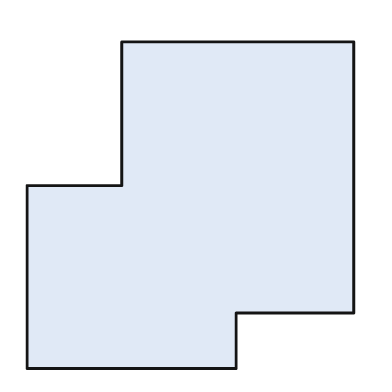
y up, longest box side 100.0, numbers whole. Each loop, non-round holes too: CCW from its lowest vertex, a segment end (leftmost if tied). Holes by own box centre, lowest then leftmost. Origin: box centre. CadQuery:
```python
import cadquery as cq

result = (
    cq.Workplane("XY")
    .moveTo(-50.0, -50.0)
    .lineTo(14.0, -50.0)
    .lineTo(14.0, -33.0)
    .lineTo(50.0, -33.0)
    .lineTo(50.0, 50.0)
    .lineTo(-21.0, 50.0)
    .lineTo(-21.0, 6.0)
    .lineTo(-50.0, 6.0)
    .close()
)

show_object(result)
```